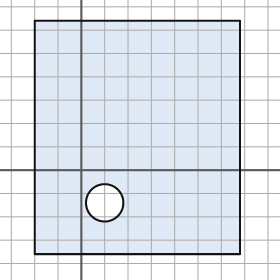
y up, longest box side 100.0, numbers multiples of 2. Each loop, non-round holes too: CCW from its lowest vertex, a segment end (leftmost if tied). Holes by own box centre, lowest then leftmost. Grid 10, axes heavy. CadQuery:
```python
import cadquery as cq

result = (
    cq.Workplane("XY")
    .moveTo(-20.0, -36.0)
    .lineTo(68.0, -36.0)
    .lineTo(68.0, 64.0)
    .lineTo(-20.0, 64.0)
    .close()
    .moveTo(10.0, -14.0)
    .circle(8.0)
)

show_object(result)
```